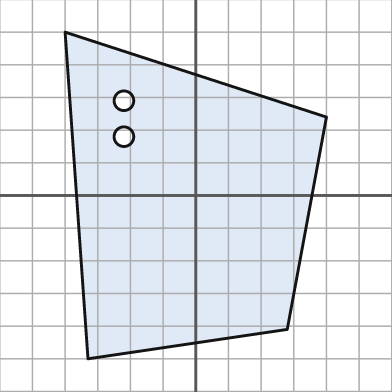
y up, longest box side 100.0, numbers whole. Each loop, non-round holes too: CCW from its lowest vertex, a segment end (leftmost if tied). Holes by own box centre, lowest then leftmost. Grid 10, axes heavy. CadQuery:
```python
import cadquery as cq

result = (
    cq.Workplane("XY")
    .moveTo(-33.0, -50.0)
    .lineTo(28.0, -41.0)
    .lineTo(40.0, 24.0)
    .lineTo(-40.0, 50.0)
    .close()
    .moveTo(-22.0, 18.0)
    .circle(3.0)
    .moveTo(-22.0, 29.0)
    .circle(3.0)
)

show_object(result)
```